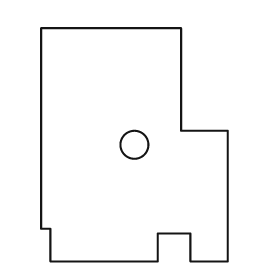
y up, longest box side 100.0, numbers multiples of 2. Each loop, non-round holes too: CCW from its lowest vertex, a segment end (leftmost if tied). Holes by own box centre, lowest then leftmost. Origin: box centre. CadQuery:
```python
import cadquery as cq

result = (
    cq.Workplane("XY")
    .moveTo(-36.0, -50.0)
    .lineTo(10.0, -50.0)
    .lineTo(10.0, -38.0)
    .lineTo(24.0, -38.0)
    .lineTo(24.0, -50.0)
    .lineTo(40.0, -50.0)
    .lineTo(40.0, 6.0)
    .lineTo(20.0, 6.0)
    .lineTo(20.0, 50.0)
    .lineTo(-40.0, 50.0)
    .lineTo(-40.0, -36.0)
    .lineTo(-36.0, -36.0)
    .close()
    .moveTo(0.0, 0.0)
    .circle(6.0)
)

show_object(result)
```